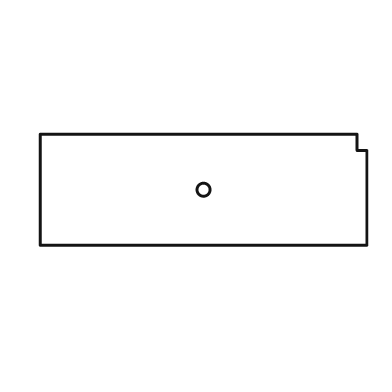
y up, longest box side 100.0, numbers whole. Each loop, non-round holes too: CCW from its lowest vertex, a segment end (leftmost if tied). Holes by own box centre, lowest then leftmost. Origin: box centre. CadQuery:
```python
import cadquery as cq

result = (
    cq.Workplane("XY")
    .moveTo(-50.0, -17.0)
    .lineTo(50.0, -17.0)
    .lineTo(50.0, 12.0)
    .lineTo(47.0, 12.0)
    .lineTo(47.0, 17.0)
    .lineTo(-50.0, 17.0)
    .close()
    .moveTo(0.0, 0.0)
    .circle(2.0)
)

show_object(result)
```